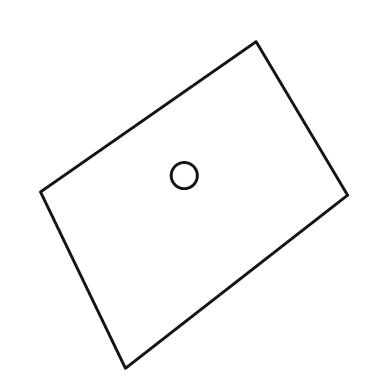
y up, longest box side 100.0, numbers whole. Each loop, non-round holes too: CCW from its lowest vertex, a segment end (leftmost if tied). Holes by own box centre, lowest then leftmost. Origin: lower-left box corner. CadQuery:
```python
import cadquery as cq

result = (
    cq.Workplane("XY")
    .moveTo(26.0, 0.0)
    .lineTo(94.0, 53.0)
    .lineTo(66.0, 100.0)
    .lineTo(0.0, 54.0)
    .close()
    .moveTo(44.0, 59.0)
    .circle(4.0)
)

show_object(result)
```